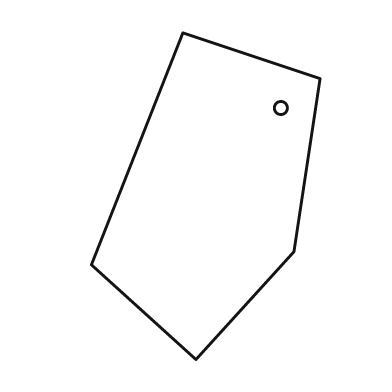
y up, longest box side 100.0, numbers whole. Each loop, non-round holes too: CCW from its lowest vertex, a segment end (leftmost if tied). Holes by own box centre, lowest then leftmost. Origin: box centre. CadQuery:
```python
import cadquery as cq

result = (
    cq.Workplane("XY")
    .moveTo(-3.0, -50.0)
    .lineTo(27.0, -17.0)
    .lineTo(35.0, 36.0)
    .lineTo(-7.0, 50.0)
    .lineTo(-35.0, -21.0)
    .close()
    .moveTo(23.0, 27.0)
    .circle(2.0)
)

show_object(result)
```